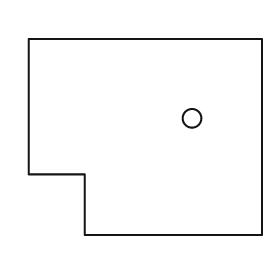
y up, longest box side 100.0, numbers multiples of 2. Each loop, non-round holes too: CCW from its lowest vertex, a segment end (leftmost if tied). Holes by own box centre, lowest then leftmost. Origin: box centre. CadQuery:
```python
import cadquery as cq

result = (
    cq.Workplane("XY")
    .moveTo(-26.0, -42.0)
    .lineTo(50.0, -42.0)
    .lineTo(50.0, 42.0)
    .lineTo(-50.0, 42.0)
    .lineTo(-50.0, -16.0)
    .lineTo(-26.0, -16.0)
    .close()
    .moveTo(20.0, 8.0)
    .circle(4.0)
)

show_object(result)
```